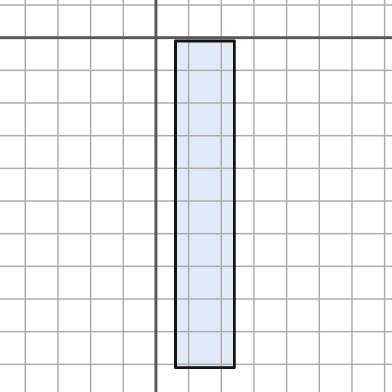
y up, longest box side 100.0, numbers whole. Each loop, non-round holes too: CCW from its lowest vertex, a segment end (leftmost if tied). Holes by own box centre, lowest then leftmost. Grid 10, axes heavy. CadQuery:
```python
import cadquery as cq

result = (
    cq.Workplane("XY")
    .moveTo(6.0, -101.0)
    .lineTo(24.0, -101.0)
    .lineTo(24.0, -1.0)
    .lineTo(6.0, -1.0)
    .close()
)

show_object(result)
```